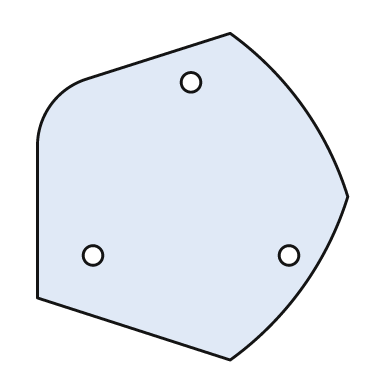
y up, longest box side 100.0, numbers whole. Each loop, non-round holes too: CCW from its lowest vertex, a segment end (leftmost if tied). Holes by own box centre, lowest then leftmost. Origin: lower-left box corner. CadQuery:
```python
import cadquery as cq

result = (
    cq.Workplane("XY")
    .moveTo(59.0, 0.0)
    .threePointArc((81.0, 22.0), (95.0, 50.0))
    .threePointArc((81.0, 78.0), (59.0, 100.0))
    .lineTo(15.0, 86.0)
    .threePointArc((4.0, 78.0), (0.0, 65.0))
    .lineTo(0.0, 19.0)
    .close()
    .moveTo(17.0, 32.0)
    .circle(3.0)
    .moveTo(77.0, 32.0)
    .circle(3.0)
    .moveTo(47.0, 85.0)
    .circle(3.0)
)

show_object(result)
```